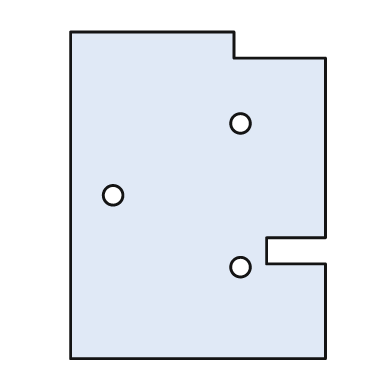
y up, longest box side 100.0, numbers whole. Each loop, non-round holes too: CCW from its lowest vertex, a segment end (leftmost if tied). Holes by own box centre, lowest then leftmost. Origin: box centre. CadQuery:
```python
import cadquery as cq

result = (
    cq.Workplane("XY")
    .moveTo(-39.0, -50.0)
    .lineTo(39.0, -50.0)
    .lineTo(39.0, -21.0)
    .lineTo(21.0, -21.0)
    .lineTo(21.0, -13.0)
    .lineTo(39.0, -13.0)
    .lineTo(39.0, 42.0)
    .lineTo(11.0, 42.0)
    .lineTo(11.0, 50.0)
    .lineTo(-39.0, 50.0)
    .close()
    .moveTo(13.0, -22.0)
    .circle(3.0)
    .moveTo(-26.0, 0.0)
    .circle(3.0)
    .moveTo(13.0, 22.0)
    .circle(3.0)
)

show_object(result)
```